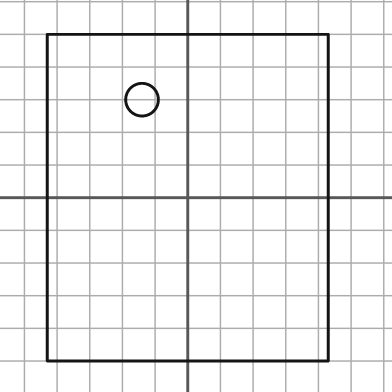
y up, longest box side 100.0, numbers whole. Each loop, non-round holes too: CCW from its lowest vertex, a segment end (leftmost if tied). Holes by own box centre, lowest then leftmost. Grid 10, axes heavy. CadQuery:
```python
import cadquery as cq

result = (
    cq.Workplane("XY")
    .moveTo(-43.0, -50.0)
    .lineTo(43.0, -50.0)
    .lineTo(43.0, 50.0)
    .lineTo(-43.0, 50.0)
    .close()
    .moveTo(-14.0, 30.0)
    .circle(5.0)
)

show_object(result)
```